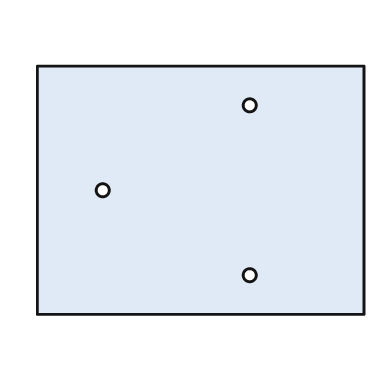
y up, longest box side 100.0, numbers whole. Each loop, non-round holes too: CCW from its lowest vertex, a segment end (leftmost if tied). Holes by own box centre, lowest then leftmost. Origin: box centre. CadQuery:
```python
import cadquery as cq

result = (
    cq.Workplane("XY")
    .moveTo(-50.0, -38.0)
    .lineTo(50.0, -38.0)
    .lineTo(50.0, 38.0)
    .lineTo(-50.0, 38.0)
    .close()
    .moveTo(15.0, -26.0)
    .circle(2.0)
    .moveTo(-30.0, 0.0)
    .circle(2.0)
    .moveTo(15.0, 26.0)
    .circle(2.0)
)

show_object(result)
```